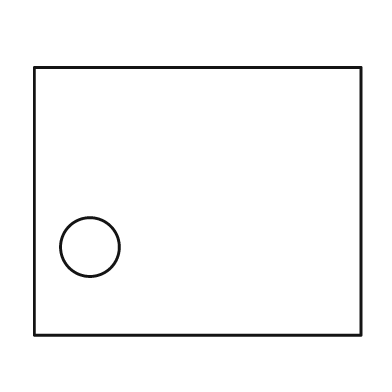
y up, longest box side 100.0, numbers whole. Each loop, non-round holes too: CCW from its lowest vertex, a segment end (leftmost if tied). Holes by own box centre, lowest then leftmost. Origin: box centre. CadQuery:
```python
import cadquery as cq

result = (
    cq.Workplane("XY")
    .moveTo(-50.0, -41.0)
    .lineTo(50.0, -41.0)
    .lineTo(50.0, 41.0)
    .lineTo(-50.0, 41.0)
    .close()
    .moveTo(-33.0, -14.0)
    .circle(9.0)
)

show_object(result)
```